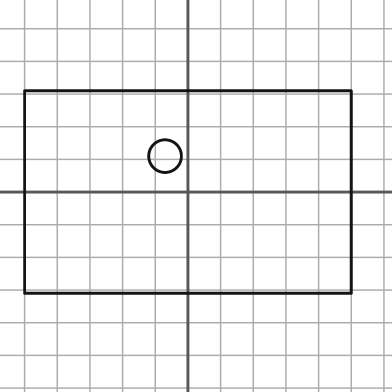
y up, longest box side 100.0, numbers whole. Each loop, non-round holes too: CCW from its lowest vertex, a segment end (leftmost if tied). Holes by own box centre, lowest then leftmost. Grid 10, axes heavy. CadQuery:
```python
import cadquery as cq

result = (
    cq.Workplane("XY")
    .moveTo(-50.0, -31.0)
    .lineTo(50.0, -31.0)
    .lineTo(50.0, 31.0)
    .lineTo(-50.0, 31.0)
    .close()
    .moveTo(-7.0, 11.0)
    .circle(5.0)
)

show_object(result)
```